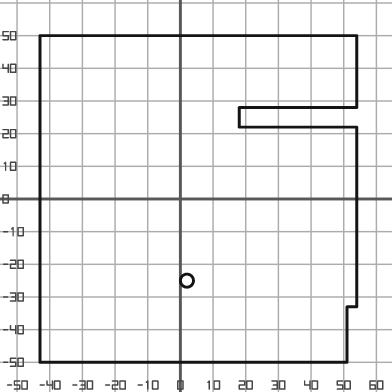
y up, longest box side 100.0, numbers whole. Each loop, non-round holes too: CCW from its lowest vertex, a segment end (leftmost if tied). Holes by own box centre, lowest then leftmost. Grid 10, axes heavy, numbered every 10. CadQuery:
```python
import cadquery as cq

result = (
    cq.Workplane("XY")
    .moveTo(-43.0, -50.0)
    .lineTo(51.0, -50.0)
    .lineTo(51.0, -33.0)
    .lineTo(54.0, -33.0)
    .lineTo(54.0, 22.0)
    .lineTo(18.0, 22.0)
    .lineTo(18.0, 28.0)
    .lineTo(54.0, 28.0)
    .lineTo(54.0, 50.0)
    .lineTo(-43.0, 50.0)
    .close()
    .moveTo(2.0, -25.0)
    .circle(2.0)
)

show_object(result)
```